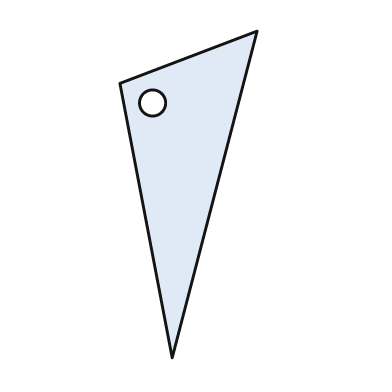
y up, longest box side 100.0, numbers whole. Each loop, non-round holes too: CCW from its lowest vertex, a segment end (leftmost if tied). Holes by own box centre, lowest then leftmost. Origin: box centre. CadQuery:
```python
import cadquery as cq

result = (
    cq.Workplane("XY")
    .moveTo(-5.0, -50.0)
    .lineTo(21.0, 50.0)
    .lineTo(-21.0, 34.0)
    .close()
    .moveTo(-11.0, 28.0)
    .circle(4.0)
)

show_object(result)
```